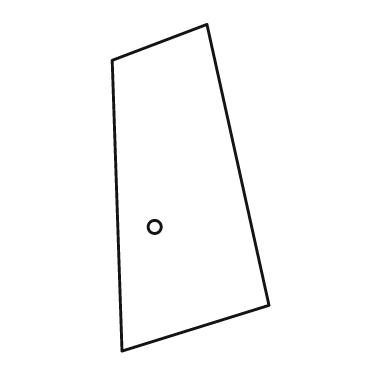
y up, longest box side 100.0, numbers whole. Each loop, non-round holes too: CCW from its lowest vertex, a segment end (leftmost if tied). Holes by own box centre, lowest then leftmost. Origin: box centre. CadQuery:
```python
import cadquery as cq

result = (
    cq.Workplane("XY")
    .moveTo(-21.0, -50.0)
    .lineTo(24.0, -36.0)
    .lineTo(5.0, 50.0)
    .lineTo(-24.0, 39.0)
    .close()
    .moveTo(-11.0, -12.0)
    .circle(2.0)
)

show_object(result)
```